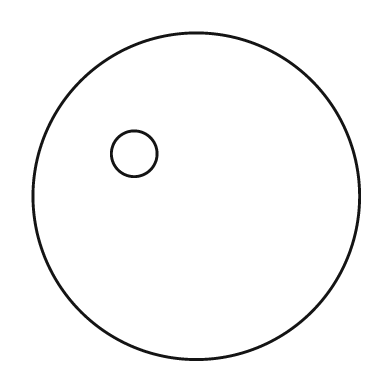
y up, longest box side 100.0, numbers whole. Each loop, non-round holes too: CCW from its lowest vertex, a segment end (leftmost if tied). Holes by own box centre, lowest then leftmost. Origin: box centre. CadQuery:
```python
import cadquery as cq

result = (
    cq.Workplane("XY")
    .moveTo(0.0, 0.0)
    .circle(50.0)
    .moveTo(-19.0, 13.0)
    .circle(7.0)
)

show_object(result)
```